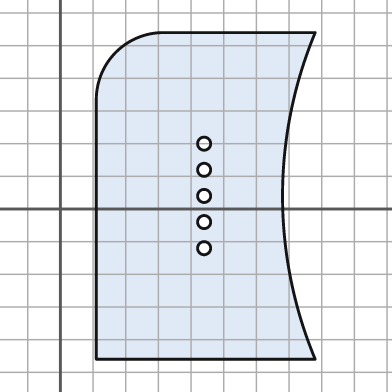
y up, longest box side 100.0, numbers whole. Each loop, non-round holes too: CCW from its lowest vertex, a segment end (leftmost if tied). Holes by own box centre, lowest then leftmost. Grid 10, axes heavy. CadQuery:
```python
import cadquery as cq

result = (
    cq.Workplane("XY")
    .moveTo(11.0, -46.0)
    .lineTo(78.0, -46.0)
    .threePointArc((68.0, 4.0), (78.0, 54.0))
    .lineTo(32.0, 54.0)
    .threePointArc((17.0, 48.0), (11.0, 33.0))
    .close()
    .moveTo(44.0, -12.0)
    .circle(2.0)
    .moveTo(44.0, -4.0)
    .circle(2.0)
    .moveTo(44.0, 4.0)
    .circle(2.0)
    .moveTo(44.0, 12.0)
    .circle(2.0)
    .moveTo(44.0, 20.0)
    .circle(2.0)
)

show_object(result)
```